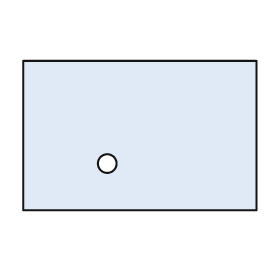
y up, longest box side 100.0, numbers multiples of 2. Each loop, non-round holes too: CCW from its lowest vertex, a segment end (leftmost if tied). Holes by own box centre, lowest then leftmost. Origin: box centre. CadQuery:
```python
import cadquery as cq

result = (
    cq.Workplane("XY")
    .moveTo(-50.0, -32.0)
    .lineTo(50.0, -32.0)
    .lineTo(50.0, 32.0)
    .lineTo(-50.0, 32.0)
    .close()
    .moveTo(-14.0, -12.0)
    .circle(4.0)
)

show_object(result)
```